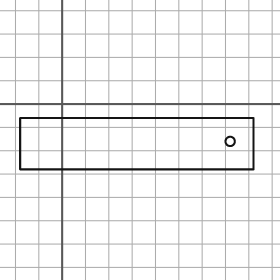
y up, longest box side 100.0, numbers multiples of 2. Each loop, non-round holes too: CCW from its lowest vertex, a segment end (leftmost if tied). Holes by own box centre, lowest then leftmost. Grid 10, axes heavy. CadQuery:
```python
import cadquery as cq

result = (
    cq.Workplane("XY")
    .moveTo(-18.0, -28.0)
    .lineTo(82.0, -28.0)
    .lineTo(82.0, -6.0)
    .lineTo(-18.0, -6.0)
    .close()
    .moveTo(72.0, -16.0)
    .circle(2.0)
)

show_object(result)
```